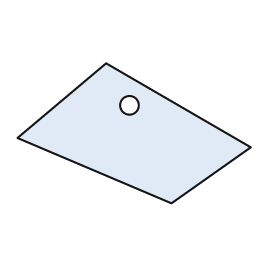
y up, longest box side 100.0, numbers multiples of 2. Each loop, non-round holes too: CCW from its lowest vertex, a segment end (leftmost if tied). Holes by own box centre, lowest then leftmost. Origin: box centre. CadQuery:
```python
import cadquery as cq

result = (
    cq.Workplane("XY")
    .moveTo(16.0, -30.0)
    .lineTo(50.0, -6.0)
    .lineTo(-12.0, 30.0)
    .lineTo(-50.0, -2.0)
    .close()
    .moveTo(-2.0, 12.0)
    .circle(4.0)
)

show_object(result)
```